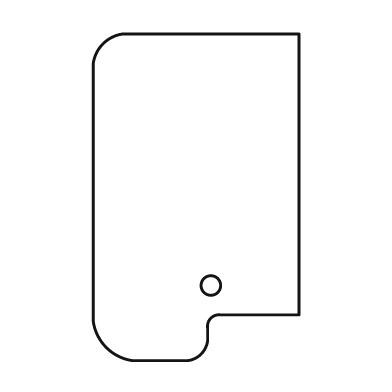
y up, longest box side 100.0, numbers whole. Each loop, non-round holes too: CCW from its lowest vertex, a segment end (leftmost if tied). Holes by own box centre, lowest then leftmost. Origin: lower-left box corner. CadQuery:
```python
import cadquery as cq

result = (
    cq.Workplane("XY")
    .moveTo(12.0, 0.0)
    .lineTo(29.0, 0.0)
    .threePointArc((33.0, 2.0), (35.0, 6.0))
    .lineTo(35.0, 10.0)
    .threePointArc((36.0, 13.0), (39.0, 14.0))
    .lineTo(63.0, 14.0)
    .lineTo(63.0, 100.0)
    .lineTo(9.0, 100.0)
    .threePointArc((3.0, 97.0), (0.0, 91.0))
    .lineTo(0.0, 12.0)
    .threePointArc((4.0, 4.0), (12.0, 0.0))
    .close()
    .moveTo(36.0, 23.0)
    .circle(3.0)
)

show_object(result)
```